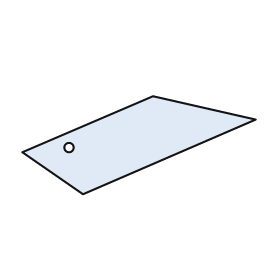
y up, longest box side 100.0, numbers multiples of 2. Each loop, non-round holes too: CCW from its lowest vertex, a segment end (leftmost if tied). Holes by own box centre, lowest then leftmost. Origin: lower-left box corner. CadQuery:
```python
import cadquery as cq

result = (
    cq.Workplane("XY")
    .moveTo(26.0, 0.0)
    .lineTo(100.0, 32.0)
    .lineTo(56.0, 42.0)
    .lineTo(0.0, 18.0)
    .close()
    .moveTo(20.0, 20.0)
    .circle(2.0)
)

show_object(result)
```